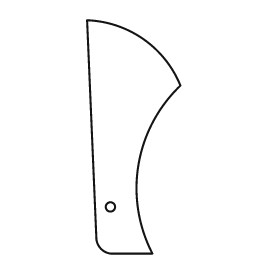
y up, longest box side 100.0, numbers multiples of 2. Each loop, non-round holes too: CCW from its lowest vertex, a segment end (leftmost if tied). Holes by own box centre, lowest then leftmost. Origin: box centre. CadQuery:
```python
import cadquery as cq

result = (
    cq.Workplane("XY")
    .moveTo(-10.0, -50.0)
    .lineTo(8.0, -50.0)
    .threePointArc((2.0, -12.0), (20.0, 22.0))
    .threePointArc((4.0, 42.0), (-20.0, 50.0))
    .lineTo(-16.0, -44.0)
    .threePointArc((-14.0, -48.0), (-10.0, -50.0))
    .close()
    .moveTo(-10.0, -30.0)
    .circle(2.0)
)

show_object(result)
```